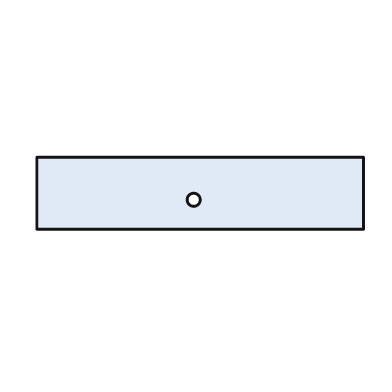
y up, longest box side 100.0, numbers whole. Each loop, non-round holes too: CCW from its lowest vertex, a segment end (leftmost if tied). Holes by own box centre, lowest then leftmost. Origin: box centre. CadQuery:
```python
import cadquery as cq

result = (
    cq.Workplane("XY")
    .moveTo(-50.0, -11.0)
    .lineTo(50.0, -11.0)
    .lineTo(50.0, 11.0)
    .lineTo(-50.0, 11.0)
    .close()
    .moveTo(-2.0, -2.0)
    .circle(2.0)
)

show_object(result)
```